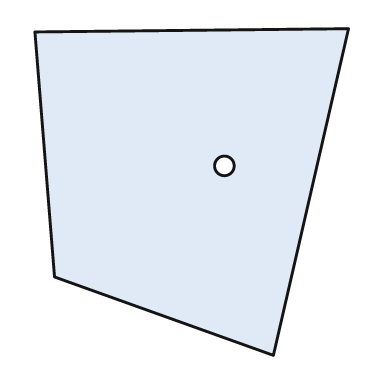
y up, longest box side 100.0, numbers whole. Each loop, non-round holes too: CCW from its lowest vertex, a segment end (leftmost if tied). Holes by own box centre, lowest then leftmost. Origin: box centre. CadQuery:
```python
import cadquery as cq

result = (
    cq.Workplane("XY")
    .moveTo(25.0, -50.0)
    .lineTo(48.0, 50.0)
    .lineTo(-48.0, 49.0)
    .lineTo(-42.0, -26.0)
    .close()
    .moveTo(10.0, 8.0)
    .circle(3.0)
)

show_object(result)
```